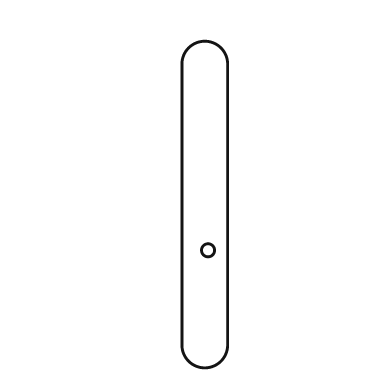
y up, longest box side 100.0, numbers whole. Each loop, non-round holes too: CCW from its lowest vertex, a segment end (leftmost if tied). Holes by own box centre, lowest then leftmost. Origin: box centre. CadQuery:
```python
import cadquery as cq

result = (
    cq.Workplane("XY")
    .moveTo(-7.0, -43.0)
    .threePointArc((0.0, -50.0), (7.0, -43.0))
    .lineTo(7.0, 43.0)
    .threePointArc((0.0, 50.0), (-7.0, 43.0))
    .close()
    .moveTo(1.0, -14.0)
    .circle(2.0)
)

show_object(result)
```